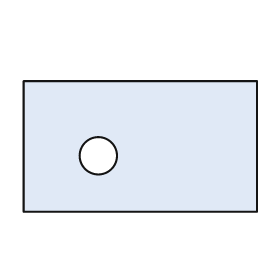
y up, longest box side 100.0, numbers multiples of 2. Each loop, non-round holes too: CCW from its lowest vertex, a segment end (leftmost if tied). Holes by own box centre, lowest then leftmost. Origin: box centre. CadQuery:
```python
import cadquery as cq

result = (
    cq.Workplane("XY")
    .moveTo(-50.0, -28.0)
    .lineTo(50.0, -28.0)
    .lineTo(50.0, 28.0)
    .lineTo(-50.0, 28.0)
    .close()
    .moveTo(-18.0, -4.0)
    .circle(8.0)
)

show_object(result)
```